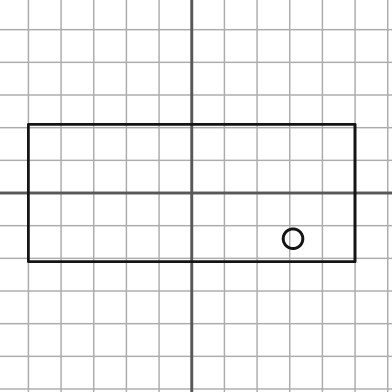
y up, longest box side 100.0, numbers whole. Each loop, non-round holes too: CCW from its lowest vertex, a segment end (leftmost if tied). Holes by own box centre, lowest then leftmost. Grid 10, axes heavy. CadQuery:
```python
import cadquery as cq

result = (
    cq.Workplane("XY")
    .moveTo(-50.0, -21.0)
    .lineTo(50.0, -21.0)
    .lineTo(50.0, 21.0)
    .lineTo(-50.0, 21.0)
    .close()
    .moveTo(31.0, -14.0)
    .circle(3.0)
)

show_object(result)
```